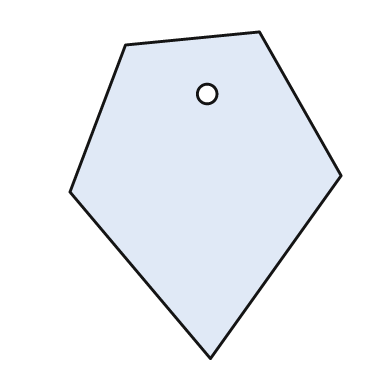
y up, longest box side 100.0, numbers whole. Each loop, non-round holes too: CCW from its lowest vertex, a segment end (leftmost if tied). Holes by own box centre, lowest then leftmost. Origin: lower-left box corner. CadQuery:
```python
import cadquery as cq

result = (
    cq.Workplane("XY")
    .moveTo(43.0, 0.0)
    .lineTo(83.0, 56.0)
    .lineTo(58.0, 100.0)
    .lineTo(17.0, 96.0)
    .lineTo(0.0, 51.0)
    .close()
    .moveTo(42.0, 81.0)
    .circle(3.0)
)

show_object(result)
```